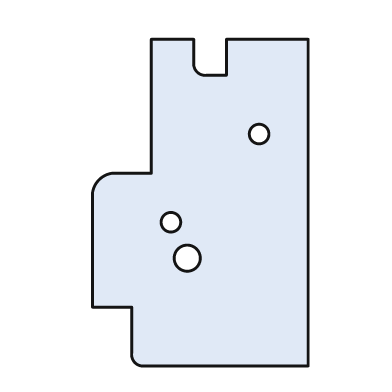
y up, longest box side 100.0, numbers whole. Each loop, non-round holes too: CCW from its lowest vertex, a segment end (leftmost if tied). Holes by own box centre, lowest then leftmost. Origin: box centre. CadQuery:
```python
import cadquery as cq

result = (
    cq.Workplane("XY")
    .moveTo(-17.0, -50.0)
    .lineTo(33.0, -50.0)
    .lineTo(33.0, 50.0)
    .lineTo(8.0, 50.0)
    .lineTo(8.0, 39.0)
    .lineTo(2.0, 39.0)
    .threePointArc((-1.0, 40.0), (-2.0, 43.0))
    .lineTo(-2.0, 50.0)
    .lineTo(-15.0, 50.0)
    .lineTo(-15.0, 9.0)
    .lineTo(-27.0, 9.0)
    .threePointArc((-31.0, 7.0), (-33.0, 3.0))
    .lineTo(-33.0, -32.0)
    .lineTo(-21.0, -32.0)
    .lineTo(-21.0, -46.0)
    .threePointArc((-20.0, -49.0), (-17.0, -50.0))
    .close()
    .moveTo(-4.0, -17.0)
    .circle(4.0)
    .moveTo(-9.0, -6.0)
    .circle(3.0)
    .moveTo(18.0, 21.0)
    .circle(3.0)
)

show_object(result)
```